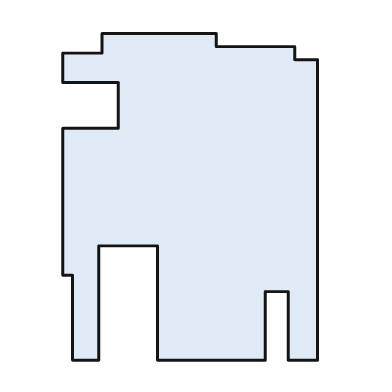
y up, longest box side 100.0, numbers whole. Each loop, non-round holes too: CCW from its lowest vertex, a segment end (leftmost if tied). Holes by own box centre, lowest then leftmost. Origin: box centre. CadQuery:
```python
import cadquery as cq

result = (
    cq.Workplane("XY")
    .moveTo(-36.0, -50.0)
    .lineTo(-28.0, -50.0)
    .lineTo(-28.0, -15.0)
    .lineTo(-10.0, -15.0)
    .lineTo(-10.0, -50.0)
    .lineTo(23.0, -50.0)
    .lineTo(23.0, -29.0)
    .lineTo(30.0, -29.0)
    .lineTo(30.0, -50.0)
    .lineTo(39.0, -50.0)
    .lineTo(39.0, 42.0)
    .lineTo(32.0, 42.0)
    .lineTo(32.0, 46.0)
    .lineTo(8.0, 46.0)
    .lineTo(8.0, 50.0)
    .lineTo(-27.0, 50.0)
    .lineTo(-27.0, 44.0)
    .lineTo(-39.0, 44.0)
    .lineTo(-39.0, 35.0)
    .lineTo(-22.0, 35.0)
    .lineTo(-22.0, 21.0)
    .lineTo(-39.0, 21.0)
    .lineTo(-39.0, -24.0)
    .lineTo(-36.0, -24.0)
    .close()
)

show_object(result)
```